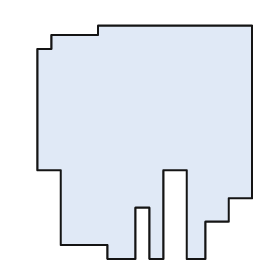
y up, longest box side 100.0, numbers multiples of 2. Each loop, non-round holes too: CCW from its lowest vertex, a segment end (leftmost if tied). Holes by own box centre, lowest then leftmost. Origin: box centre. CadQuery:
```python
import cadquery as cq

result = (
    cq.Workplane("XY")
    .moveTo(-16.0, -50.0)
    .lineTo(-4.0, -50.0)
    .lineTo(-4.0, -28.0)
    .lineTo(2.0, -28.0)
    .lineTo(2.0, -50.0)
    .lineTo(8.0, -50.0)
    .lineTo(8.0, -12.0)
    .lineTo(18.0, -12.0)
    .lineTo(18.0, -50.0)
    .lineTo(26.0, -50.0)
    .lineTo(26.0, -34.0)
    .lineTo(36.0, -34.0)
    .lineTo(36.0, -24.0)
    .lineTo(46.0, -24.0)
    .lineTo(46.0, 50.0)
    .lineTo(-20.0, 50.0)
    .lineTo(-20.0, 46.0)
    .lineTo(-40.0, 46.0)
    .lineTo(-40.0, 40.0)
    .lineTo(-46.0, 40.0)
    .lineTo(-46.0, -12.0)
    .lineTo(-36.0, -12.0)
    .lineTo(-36.0, -44.0)
    .lineTo(-16.0, -44.0)
    .close()
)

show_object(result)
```